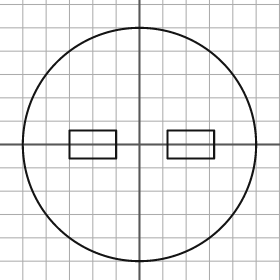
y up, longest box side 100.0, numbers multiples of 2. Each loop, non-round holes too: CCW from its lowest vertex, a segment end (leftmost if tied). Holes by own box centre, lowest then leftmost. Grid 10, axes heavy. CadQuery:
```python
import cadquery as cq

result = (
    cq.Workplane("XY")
    .moveTo(0.0, 0.0)
    .circle(50.0)
    .moveTo(-30.0, -6.0)
    .lineTo(-10.0, -6.0)
    .lineTo(-10.0, 6.0)
    .lineTo(-30.0, 6.0)
    .close()
    .moveTo(12.0, -6.0)
    .lineTo(32.0, -6.0)
    .lineTo(32.0, 6.0)
    .lineTo(12.0, 6.0)
    .close()
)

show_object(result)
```